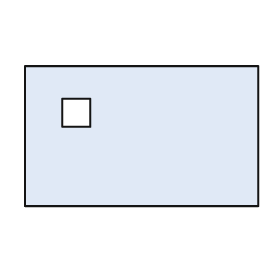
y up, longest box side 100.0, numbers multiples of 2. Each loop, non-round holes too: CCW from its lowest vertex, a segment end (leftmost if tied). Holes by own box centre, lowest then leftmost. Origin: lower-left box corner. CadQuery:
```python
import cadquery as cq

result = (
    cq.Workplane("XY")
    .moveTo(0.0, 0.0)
    .lineTo(100.0, 0.0)
    .lineTo(100.0, 60.0)
    .lineTo(0.0, 60.0)
    .close()
    .moveTo(16.0, 34.0)
    .lineTo(28.0, 34.0)
    .lineTo(28.0, 46.0)
    .lineTo(16.0, 46.0)
    .close()
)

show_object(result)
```